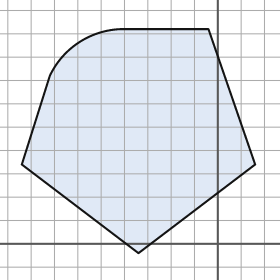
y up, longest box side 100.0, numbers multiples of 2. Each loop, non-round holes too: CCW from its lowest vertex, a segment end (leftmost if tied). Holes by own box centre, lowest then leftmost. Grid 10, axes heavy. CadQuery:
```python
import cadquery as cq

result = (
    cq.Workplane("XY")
    .moveTo(-34.0, -4.0)
    .lineTo(16.0, 34.0)
    .lineTo(-4.0, 92.0)
    .lineTo(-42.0, 92.0)
    .threePointArc((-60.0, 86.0), (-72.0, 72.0))
    .lineTo(-84.0, 34.0)
    .close()
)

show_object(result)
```